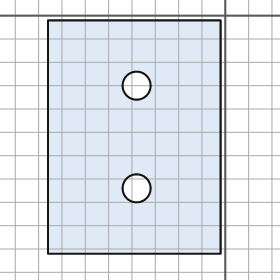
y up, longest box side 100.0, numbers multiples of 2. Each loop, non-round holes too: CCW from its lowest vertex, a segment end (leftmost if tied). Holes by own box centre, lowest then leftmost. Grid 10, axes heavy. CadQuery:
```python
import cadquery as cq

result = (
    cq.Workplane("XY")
    .moveTo(-76.0, -102.0)
    .lineTo(-2.0, -102.0)
    .lineTo(-2.0, -2.0)
    .lineTo(-76.0, -2.0)
    .close()
    .moveTo(-38.0, -74.0)
    .circle(6.0)
    .moveTo(-38.0, -30.0)
    .circle(6.0)
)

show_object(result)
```